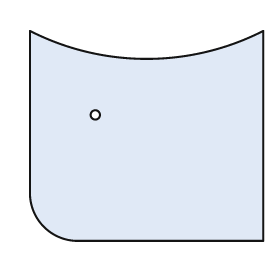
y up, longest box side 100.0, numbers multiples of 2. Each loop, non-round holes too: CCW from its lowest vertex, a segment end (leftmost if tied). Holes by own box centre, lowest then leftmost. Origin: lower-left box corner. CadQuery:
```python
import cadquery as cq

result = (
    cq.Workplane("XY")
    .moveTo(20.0, 0.0)
    .lineTo(100.0, 0.0)
    .lineTo(100.0, 90.0)
    .threePointArc((50.0, 78.0), (0.0, 90.0))
    .lineTo(0.0, 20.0)
    .threePointArc((6.0, 6.0), (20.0, 0.0))
    .close()
    .moveTo(28.0, 54.0)
    .circle(2.0)
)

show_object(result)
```